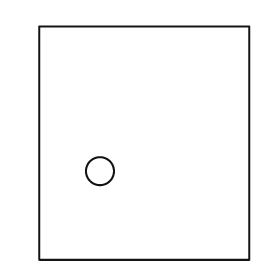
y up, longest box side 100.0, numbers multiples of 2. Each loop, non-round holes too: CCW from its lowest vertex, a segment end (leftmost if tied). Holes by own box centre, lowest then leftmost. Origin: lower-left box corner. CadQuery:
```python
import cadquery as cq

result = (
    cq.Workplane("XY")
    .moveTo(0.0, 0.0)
    .lineTo(90.0, 0.0)
    .lineTo(90.0, 100.0)
    .lineTo(0.0, 100.0)
    .close()
    .moveTo(26.0, 38.0)
    .circle(6.0)
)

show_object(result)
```